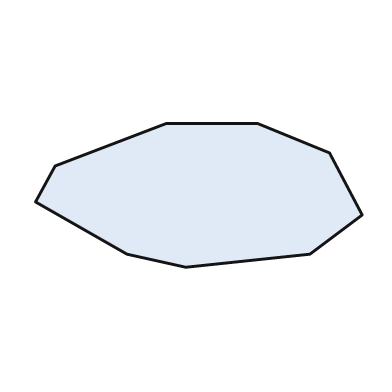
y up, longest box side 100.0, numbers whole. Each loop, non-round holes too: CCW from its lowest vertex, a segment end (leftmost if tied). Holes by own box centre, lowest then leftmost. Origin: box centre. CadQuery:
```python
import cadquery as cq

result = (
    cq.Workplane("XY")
    .moveTo(-4.0, -22.0)
    .lineTo(34.0, -18.0)
    .lineTo(50.0, -6.0)
    .lineTo(40.0, 13.0)
    .lineTo(18.0, 22.0)
    .lineTo(-10.0, 22.0)
    .lineTo(-44.0, 9.0)
    .lineTo(-50.0, -2.0)
    .lineTo(-22.0, -18.0)
    .close()
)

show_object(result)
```